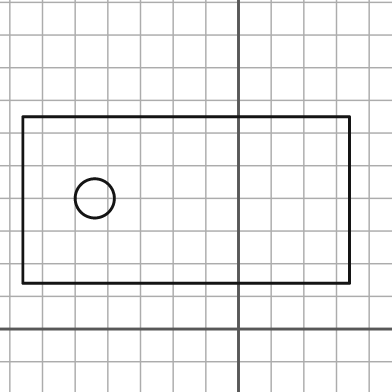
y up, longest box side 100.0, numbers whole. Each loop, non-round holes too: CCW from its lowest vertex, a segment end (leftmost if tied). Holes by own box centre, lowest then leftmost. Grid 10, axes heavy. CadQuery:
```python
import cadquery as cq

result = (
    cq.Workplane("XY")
    .moveTo(-66.0, 14.0)
    .lineTo(34.0, 14.0)
    .lineTo(34.0, 65.0)
    .lineTo(-66.0, 65.0)
    .close()
    .moveTo(-44.0, 40.0)
    .circle(6.0)
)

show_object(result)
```